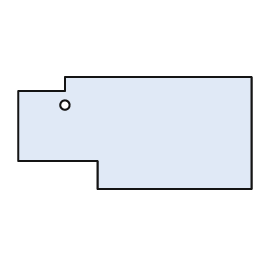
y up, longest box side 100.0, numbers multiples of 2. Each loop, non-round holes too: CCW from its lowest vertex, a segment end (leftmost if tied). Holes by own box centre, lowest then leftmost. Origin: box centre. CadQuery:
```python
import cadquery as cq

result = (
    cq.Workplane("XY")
    .moveTo(-16.0, -24.0)
    .lineTo(50.0, -24.0)
    .lineTo(50.0, 24.0)
    .lineTo(-30.0, 24.0)
    .lineTo(-30.0, 18.0)
    .lineTo(-50.0, 18.0)
    .lineTo(-50.0, -12.0)
    .lineTo(-16.0, -12.0)
    .close()
    .moveTo(-30.0, 12.0)
    .circle(2.0)
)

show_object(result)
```